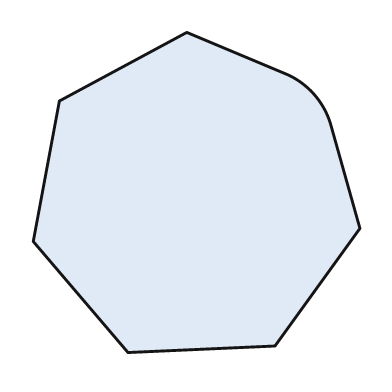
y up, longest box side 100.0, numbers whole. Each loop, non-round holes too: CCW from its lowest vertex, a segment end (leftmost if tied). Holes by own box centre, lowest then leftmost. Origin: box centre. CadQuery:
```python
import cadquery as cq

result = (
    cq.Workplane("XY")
    .moveTo(-21.0, -49.0)
    .lineTo(24.0, -47.0)
    .lineTo(50.0, -11.0)
    .lineTo(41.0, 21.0)
    .threePointArc((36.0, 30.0), (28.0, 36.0))
    .lineTo(-3.0, 49.0)
    .lineTo(-42.0, 28.0)
    .lineTo(-50.0, -15.0)
    .close()
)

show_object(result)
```